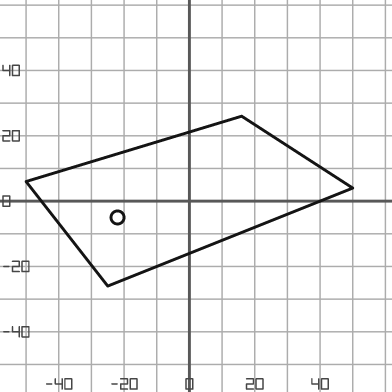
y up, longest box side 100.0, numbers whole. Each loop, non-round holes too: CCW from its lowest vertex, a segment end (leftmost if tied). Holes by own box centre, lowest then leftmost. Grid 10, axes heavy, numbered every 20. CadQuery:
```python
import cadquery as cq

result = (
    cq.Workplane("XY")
    .moveTo(-25.0, -26.0)
    .lineTo(50.0, 4.0)
    .lineTo(16.0, 26.0)
    .lineTo(-50.0, 6.0)
    .close()
    .moveTo(-22.0, -5.0)
    .circle(2.0)
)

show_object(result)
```